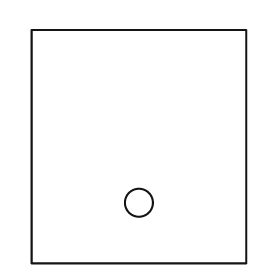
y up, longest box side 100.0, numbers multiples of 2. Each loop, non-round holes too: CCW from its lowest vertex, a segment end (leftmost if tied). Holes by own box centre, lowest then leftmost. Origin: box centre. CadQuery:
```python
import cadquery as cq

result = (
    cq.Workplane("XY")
    .moveTo(-46.0, -50.0)
    .lineTo(46.0, -50.0)
    .lineTo(46.0, 50.0)
    .lineTo(-46.0, 50.0)
    .close()
    .moveTo(0.0, -24.0)
    .circle(6.0)
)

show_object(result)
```